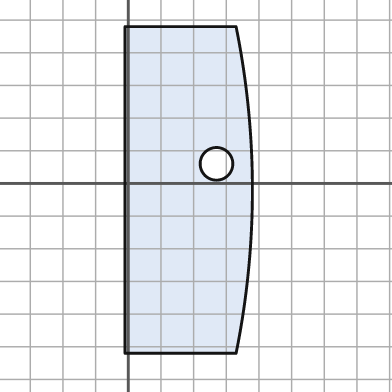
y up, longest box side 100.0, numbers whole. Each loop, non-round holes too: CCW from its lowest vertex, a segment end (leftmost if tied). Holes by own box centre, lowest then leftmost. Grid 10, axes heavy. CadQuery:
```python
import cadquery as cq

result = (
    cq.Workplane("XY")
    .moveTo(-1.0, -52.0)
    .lineTo(33.0, -52.0)
    .threePointArc((38.0, -2.0), (33.0, 48.0))
    .lineTo(-1.0, 48.0)
    .close()
    .moveTo(27.0, 6.0)
    .circle(5.0)
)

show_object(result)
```